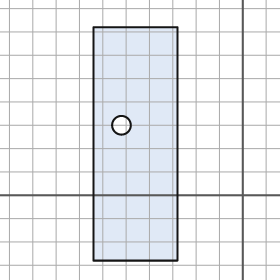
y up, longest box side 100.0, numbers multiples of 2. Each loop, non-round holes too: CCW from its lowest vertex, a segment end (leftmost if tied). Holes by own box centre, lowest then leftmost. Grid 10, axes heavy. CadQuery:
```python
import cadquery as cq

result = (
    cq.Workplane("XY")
    .moveTo(-64.0, -28.0)
    .lineTo(-28.0, -28.0)
    .lineTo(-28.0, 72.0)
    .lineTo(-64.0, 72.0)
    .close()
    .moveTo(-52.0, 30.0)
    .circle(4.0)
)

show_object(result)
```